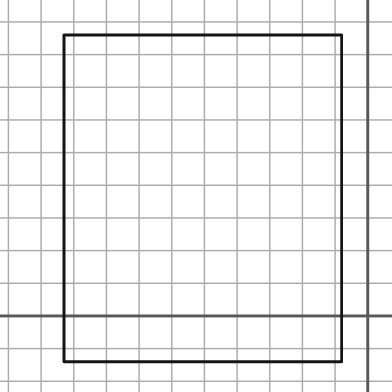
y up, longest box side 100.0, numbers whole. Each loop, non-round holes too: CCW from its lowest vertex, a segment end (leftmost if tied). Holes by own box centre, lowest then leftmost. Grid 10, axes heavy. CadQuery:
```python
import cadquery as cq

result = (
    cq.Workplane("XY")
    .moveTo(-93.0, -14.0)
    .lineTo(-8.0, -14.0)
    .lineTo(-8.0, 86.0)
    .lineTo(-93.0, 86.0)
    .close()
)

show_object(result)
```